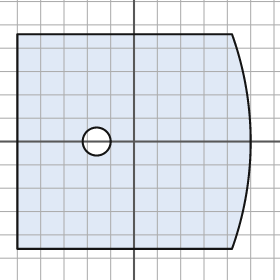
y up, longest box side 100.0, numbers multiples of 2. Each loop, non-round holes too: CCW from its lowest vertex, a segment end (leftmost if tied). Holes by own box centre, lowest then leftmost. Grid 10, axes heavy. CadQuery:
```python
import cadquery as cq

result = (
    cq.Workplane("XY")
    .moveTo(-50.0, -46.0)
    .lineTo(42.0, -46.0)
    .threePointArc((50.0, 0.0), (42.0, 46.0))
    .lineTo(-50.0, 46.0)
    .close()
    .moveTo(-16.0, 0.0)
    .circle(6.0)
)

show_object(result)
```